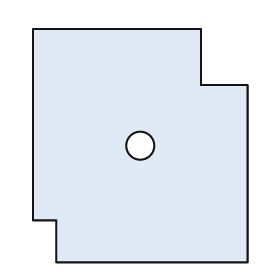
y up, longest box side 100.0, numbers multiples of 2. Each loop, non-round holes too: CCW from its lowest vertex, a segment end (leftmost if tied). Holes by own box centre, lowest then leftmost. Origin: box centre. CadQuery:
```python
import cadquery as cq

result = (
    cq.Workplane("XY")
    .moveTo(-36.0, -50.0)
    .lineTo(46.0, -50.0)
    .lineTo(46.0, 26.0)
    .lineTo(26.0, 26.0)
    .lineTo(26.0, 50.0)
    .lineTo(-46.0, 50.0)
    .lineTo(-46.0, -32.0)
    .lineTo(-36.0, -32.0)
    .close()
    .moveTo(0.0, 0.0)
    .circle(6.0)
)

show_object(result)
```